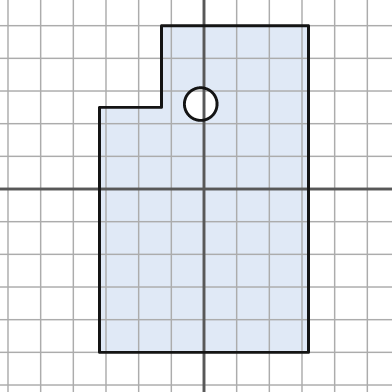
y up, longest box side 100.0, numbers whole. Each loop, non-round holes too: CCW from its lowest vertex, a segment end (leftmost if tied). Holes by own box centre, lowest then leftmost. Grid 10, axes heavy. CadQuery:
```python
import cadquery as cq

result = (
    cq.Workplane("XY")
    .moveTo(-32.0, -50.0)
    .lineTo(32.0, -50.0)
    .lineTo(32.0, 50.0)
    .lineTo(-13.0, 50.0)
    .lineTo(-13.0, 25.0)
    .lineTo(-32.0, 25.0)
    .close()
    .moveTo(-1.0, 26.0)
    .circle(5.0)
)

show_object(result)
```